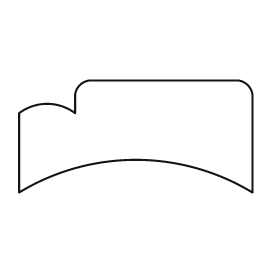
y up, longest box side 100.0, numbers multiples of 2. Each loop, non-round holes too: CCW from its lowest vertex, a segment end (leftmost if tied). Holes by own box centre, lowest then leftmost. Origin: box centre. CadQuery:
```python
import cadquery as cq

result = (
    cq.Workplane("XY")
    .moveTo(-50.0, -24.0)
    .threePointArc((0.0, -10.0), (50.0, -24.0))
    .lineTo(50.0, 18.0)
    .threePointArc((48.0, 22.0), (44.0, 24.0))
    .lineTo(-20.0, 24.0)
    .threePointArc((-24.0, 22.0), (-26.0, 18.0))
    .lineTo(-26.0, 10.0)
    .threePointArc((-38.0, 14.0), (-50.0, 10.0))
    .close()
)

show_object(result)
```